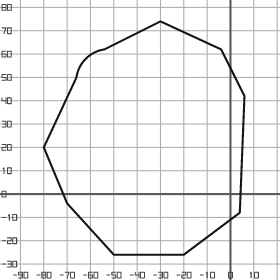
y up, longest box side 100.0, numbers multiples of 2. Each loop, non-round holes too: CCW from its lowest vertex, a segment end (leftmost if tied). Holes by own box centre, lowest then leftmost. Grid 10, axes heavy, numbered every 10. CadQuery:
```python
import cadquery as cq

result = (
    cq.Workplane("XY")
    .moveTo(-50.0, -26.0)
    .lineTo(-20.0, -26.0)
    .lineTo(4.0, -8.0)
    .lineTo(6.0, 42.0)
    .lineTo(-4.0, 62.0)
    .lineTo(-30.0, 74.0)
    .lineTo(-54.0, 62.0)
    .threePointArc((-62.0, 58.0), (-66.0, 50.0))
    .lineTo(-80.0, 20.0)
    .lineTo(-70.0, -4.0)
    .close()
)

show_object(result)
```